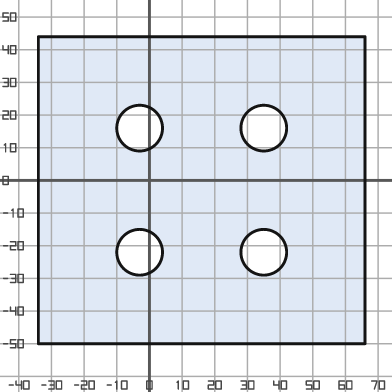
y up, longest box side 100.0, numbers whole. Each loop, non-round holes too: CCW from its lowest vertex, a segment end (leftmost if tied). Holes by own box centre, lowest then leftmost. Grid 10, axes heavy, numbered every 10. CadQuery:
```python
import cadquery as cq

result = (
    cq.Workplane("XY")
    .moveTo(-34.0, -50.0)
    .lineTo(66.0, -50.0)
    .lineTo(66.0, 44.0)
    .lineTo(-34.0, 44.0)
    .close()
    .moveTo(-3.0, -22.0)
    .circle(7.0)
    .moveTo(35.0, -22.0)
    .circle(7.0)
    .moveTo(-3.0, 16.0)
    .circle(7.0)
    .moveTo(35.0, 16.0)
    .circle(7.0)
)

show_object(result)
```